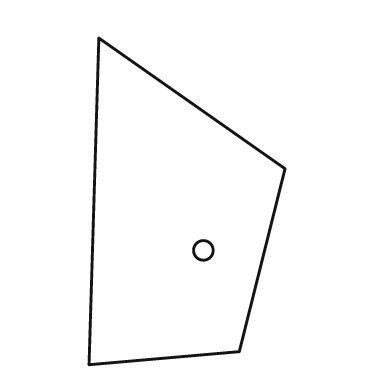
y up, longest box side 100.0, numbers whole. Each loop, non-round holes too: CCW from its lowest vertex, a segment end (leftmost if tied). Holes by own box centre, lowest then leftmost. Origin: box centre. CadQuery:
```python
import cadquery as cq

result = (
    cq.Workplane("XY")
    .moveTo(-30.0, -50.0)
    .lineTo(16.0, -46.0)
    .lineTo(30.0, 10.0)
    .lineTo(-27.0, 50.0)
    .close()
    .moveTo(5.0, -15.0)
    .circle(3.0)
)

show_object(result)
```